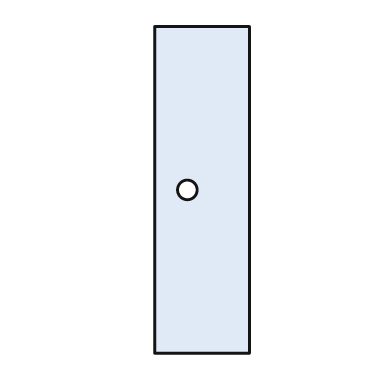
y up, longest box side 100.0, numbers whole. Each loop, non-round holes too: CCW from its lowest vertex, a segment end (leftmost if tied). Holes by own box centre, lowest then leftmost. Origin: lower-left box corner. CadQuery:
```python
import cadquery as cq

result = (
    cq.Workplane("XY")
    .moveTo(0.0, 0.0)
    .lineTo(29.0, 0.0)
    .lineTo(29.0, 100.0)
    .lineTo(0.0, 100.0)
    .close()
    .moveTo(10.0, 50.0)
    .circle(3.0)
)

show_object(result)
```